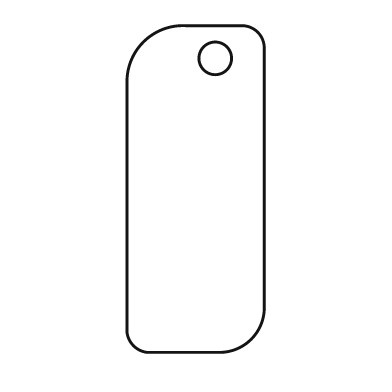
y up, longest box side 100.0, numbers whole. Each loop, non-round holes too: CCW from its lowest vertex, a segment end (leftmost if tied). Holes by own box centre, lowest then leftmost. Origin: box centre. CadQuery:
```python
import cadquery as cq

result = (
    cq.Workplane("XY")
    .moveTo(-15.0, -50.0)
    .lineTo(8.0, -50.0)
    .threePointArc((17.0, -46.0), (21.0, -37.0))
    .lineTo(21.0, 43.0)
    .threePointArc((19.0, 48.0), (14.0, 50.0))
    .lineTo(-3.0, 50.0)
    .threePointArc((-16.0, 45.0), (-21.0, 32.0))
    .lineTo(-21.0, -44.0)
    .threePointArc((-19.0, -48.0), (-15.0, -50.0))
    .close()
    .moveTo(6.0, 40.0)
    .circle(5.0)
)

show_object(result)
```